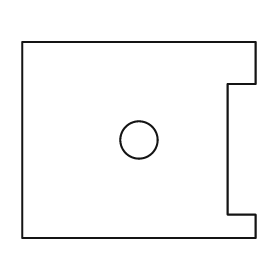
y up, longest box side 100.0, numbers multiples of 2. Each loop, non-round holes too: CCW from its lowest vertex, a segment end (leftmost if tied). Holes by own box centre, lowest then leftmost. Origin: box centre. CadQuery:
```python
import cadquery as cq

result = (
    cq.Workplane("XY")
    .moveTo(-50.0, -42.0)
    .lineTo(50.0, -42.0)
    .lineTo(50.0, -32.0)
    .lineTo(38.0, -32.0)
    .lineTo(38.0, 24.0)
    .lineTo(50.0, 24.0)
    .lineTo(50.0, 42.0)
    .lineTo(-50.0, 42.0)
    .close()
    .moveTo(0.0, 0.0)
    .circle(8.0)
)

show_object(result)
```